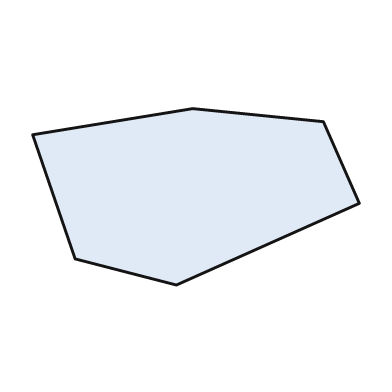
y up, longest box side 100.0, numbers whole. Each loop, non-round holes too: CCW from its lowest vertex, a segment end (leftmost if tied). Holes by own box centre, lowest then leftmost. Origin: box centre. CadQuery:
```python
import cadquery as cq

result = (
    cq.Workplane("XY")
    .moveTo(-6.0, -27.0)
    .lineTo(50.0, -2.0)
    .lineTo(39.0, 23.0)
    .lineTo(-1.0, 27.0)
    .lineTo(-50.0, 19.0)
    .lineTo(-37.0, -19.0)
    .close()
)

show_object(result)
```